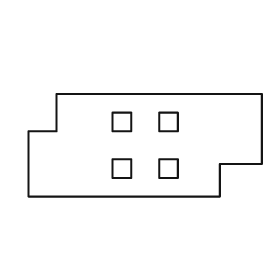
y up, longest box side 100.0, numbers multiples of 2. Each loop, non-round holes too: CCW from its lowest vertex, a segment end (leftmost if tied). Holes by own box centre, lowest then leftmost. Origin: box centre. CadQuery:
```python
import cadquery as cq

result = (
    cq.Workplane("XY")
    .moveTo(-50.0, -22.0)
    .lineTo(32.0, -22.0)
    .lineTo(32.0, -8.0)
    .lineTo(50.0, -8.0)
    .lineTo(50.0, 22.0)
    .lineTo(-38.0, 22.0)
    .lineTo(-38.0, 6.0)
    .lineTo(-50.0, 6.0)
    .close()
    .moveTo(-14.0, -14.0)
    .lineTo(-6.0, -14.0)
    .lineTo(-6.0, -6.0)
    .lineTo(-14.0, -6.0)
    .close()
    .moveTo(6.0, -14.0)
    .lineTo(14.0, -14.0)
    .lineTo(14.0, -6.0)
    .lineTo(6.0, -6.0)
    .close()
    .moveTo(-14.0, 6.0)
    .lineTo(-6.0, 6.0)
    .lineTo(-6.0, 14.0)
    .lineTo(-14.0, 14.0)
    .close()
    .moveTo(6.0, 6.0)
    .lineTo(14.0, 6.0)
    .lineTo(14.0, 14.0)
    .lineTo(6.0, 14.0)
    .close()
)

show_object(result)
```